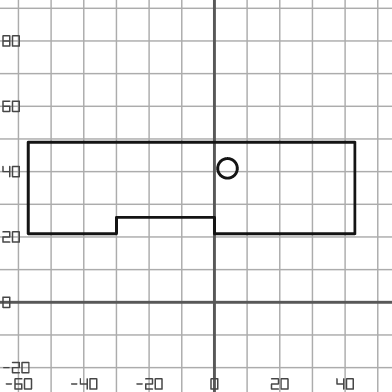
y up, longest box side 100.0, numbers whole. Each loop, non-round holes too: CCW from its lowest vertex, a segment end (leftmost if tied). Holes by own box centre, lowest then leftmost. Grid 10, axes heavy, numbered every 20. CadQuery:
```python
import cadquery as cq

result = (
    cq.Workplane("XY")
    .moveTo(-57.0, 21.0)
    .lineTo(-30.0, 21.0)
    .lineTo(-30.0, 26.0)
    .lineTo(0.0, 26.0)
    .lineTo(0.0, 21.0)
    .lineTo(43.0, 21.0)
    .lineTo(43.0, 49.0)
    .lineTo(-57.0, 49.0)
    .close()
    .moveTo(4.0, 41.0)
    .circle(3.0)
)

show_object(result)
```